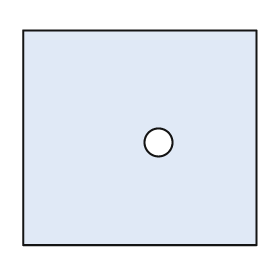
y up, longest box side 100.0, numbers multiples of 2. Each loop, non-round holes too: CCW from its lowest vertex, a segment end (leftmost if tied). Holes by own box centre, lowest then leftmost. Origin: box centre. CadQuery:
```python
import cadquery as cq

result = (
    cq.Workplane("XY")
    .moveTo(-50.0, -46.0)
    .lineTo(50.0, -46.0)
    .lineTo(50.0, 46.0)
    .lineTo(-50.0, 46.0)
    .close()
    .moveTo(8.0, -2.0)
    .circle(6.0)
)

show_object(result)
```